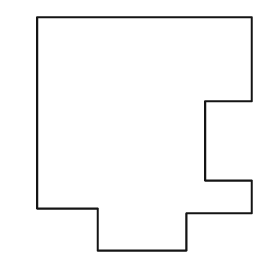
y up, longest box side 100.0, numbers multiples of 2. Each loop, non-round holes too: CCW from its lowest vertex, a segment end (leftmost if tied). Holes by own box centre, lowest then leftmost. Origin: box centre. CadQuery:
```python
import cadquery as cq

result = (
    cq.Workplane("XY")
    .moveTo(-20.0, -50.0)
    .lineTo(18.0, -50.0)
    .lineTo(18.0, -34.0)
    .lineTo(46.0, -34.0)
    .lineTo(46.0, -20.0)
    .lineTo(26.0, -20.0)
    .lineTo(26.0, 14.0)
    .lineTo(46.0, 14.0)
    .lineTo(46.0, 50.0)
    .lineTo(-46.0, 50.0)
    .lineTo(-46.0, -32.0)
    .lineTo(-20.0, -32.0)
    .close()
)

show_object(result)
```